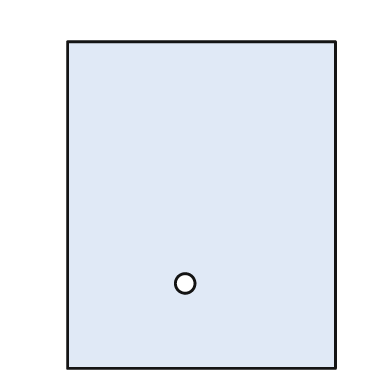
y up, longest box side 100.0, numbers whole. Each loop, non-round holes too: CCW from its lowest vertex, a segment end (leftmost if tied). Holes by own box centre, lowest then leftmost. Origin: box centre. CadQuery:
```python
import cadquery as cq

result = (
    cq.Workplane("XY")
    .moveTo(-41.0, -50.0)
    .lineTo(41.0, -50.0)
    .lineTo(41.0, 50.0)
    .lineTo(-41.0, 50.0)
    .close()
    .moveTo(-5.0, -24.0)
    .circle(3.0)
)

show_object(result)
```